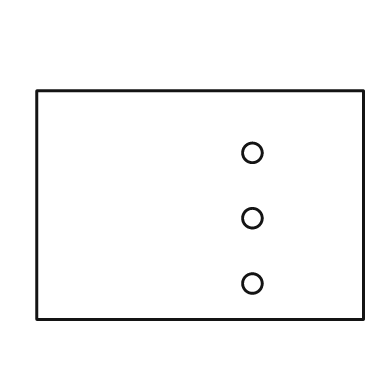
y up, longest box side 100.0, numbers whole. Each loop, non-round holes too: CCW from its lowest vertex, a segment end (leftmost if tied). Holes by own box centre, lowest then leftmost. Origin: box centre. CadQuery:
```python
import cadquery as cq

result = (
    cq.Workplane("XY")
    .moveTo(-50.0, -35.0)
    .lineTo(50.0, -35.0)
    .lineTo(50.0, 35.0)
    .lineTo(-50.0, 35.0)
    .close()
    .moveTo(16.0, -24.0)
    .circle(3.0)
    .moveTo(16.0, -4.0)
    .circle(3.0)
    .moveTo(16.0, 16.0)
    .circle(3.0)
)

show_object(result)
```